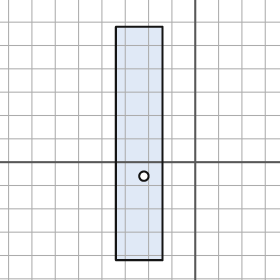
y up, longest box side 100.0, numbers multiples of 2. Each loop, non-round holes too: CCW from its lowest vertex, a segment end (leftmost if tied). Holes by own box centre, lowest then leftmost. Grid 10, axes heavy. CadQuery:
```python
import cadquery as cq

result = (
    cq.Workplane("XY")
    .moveTo(-34.0, -42.0)
    .lineTo(-14.0, -42.0)
    .lineTo(-14.0, 58.0)
    .lineTo(-34.0, 58.0)
    .close()
    .moveTo(-22.0, -6.0)
    .circle(2.0)
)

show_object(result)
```